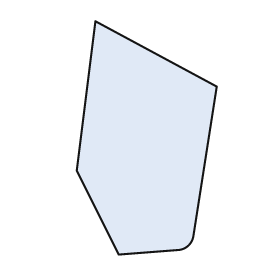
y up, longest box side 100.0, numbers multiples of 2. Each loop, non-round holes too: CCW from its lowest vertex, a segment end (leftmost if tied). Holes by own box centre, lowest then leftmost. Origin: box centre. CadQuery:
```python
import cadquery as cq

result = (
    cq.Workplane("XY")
    .moveTo(-12.0, -50.0)
    .lineTo(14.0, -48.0)
    .threePointArc((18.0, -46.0), (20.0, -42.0))
    .lineTo(30.0, 22.0)
    .lineTo(-22.0, 50.0)
    .lineTo(-30.0, -14.0)
    .close()
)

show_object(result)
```